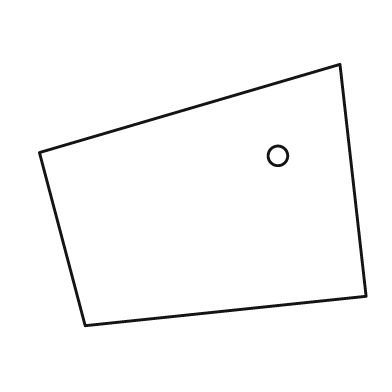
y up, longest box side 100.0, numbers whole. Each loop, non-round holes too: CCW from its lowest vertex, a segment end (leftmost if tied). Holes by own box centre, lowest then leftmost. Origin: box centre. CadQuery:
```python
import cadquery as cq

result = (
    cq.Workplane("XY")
    .moveTo(-36.0, -40.0)
    .lineTo(50.0, -31.0)
    .lineTo(42.0, 40.0)
    .lineTo(-50.0, 13.0)
    .close()
    .moveTo(23.0, 12.0)
    .circle(3.0)
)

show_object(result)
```